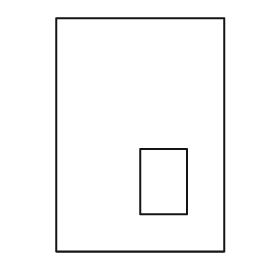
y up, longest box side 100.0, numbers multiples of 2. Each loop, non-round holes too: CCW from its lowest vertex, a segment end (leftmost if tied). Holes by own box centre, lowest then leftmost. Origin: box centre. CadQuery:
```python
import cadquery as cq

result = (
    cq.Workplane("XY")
    .moveTo(-36.0, -50.0)
    .lineTo(36.0, -50.0)
    .lineTo(36.0, 50.0)
    .lineTo(-36.0, 50.0)
    .close()
    .moveTo(0.0, -34.0)
    .lineTo(20.0, -34.0)
    .lineTo(20.0, -6.0)
    .lineTo(0.0, -6.0)
    .close()
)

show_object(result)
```